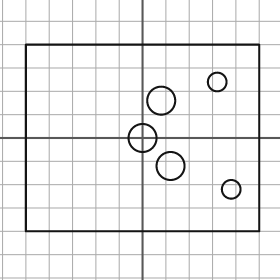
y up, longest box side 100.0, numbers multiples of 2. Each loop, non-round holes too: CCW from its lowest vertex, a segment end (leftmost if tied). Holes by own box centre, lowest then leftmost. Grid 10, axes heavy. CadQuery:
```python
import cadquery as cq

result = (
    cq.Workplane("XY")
    .moveTo(-50.0, -40.0)
    .lineTo(50.0, -40.0)
    .lineTo(50.0, 40.0)
    .lineTo(-50.0, 40.0)
    .close()
    .moveTo(38.0, -22.0)
    .circle(4.0)
    .moveTo(12.0, -12.0)
    .circle(6.0)
    .moveTo(0.0, 0.0)
    .circle(6.0)
    .moveTo(8.0, 16.0)
    .circle(6.0)
    .moveTo(32.0, 24.0)
    .circle(4.0)
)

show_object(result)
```